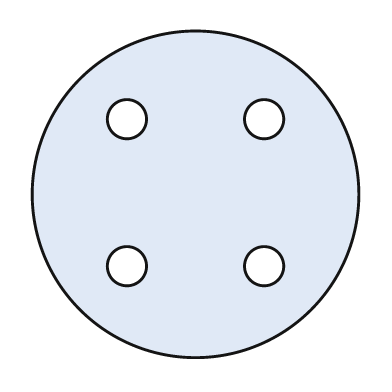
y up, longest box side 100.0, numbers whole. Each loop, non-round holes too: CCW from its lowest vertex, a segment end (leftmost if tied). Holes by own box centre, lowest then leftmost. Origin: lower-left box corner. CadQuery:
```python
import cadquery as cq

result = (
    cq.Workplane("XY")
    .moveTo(50.0, 50.0)
    .circle(50.0)
    .moveTo(29.0, 28.0)
    .circle(6.0)
    .moveTo(71.0, 28.0)
    .circle(6.0)
    .moveTo(29.0, 73.0)
    .circle(6.0)
    .moveTo(71.0, 73.0)
    .circle(6.0)
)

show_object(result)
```